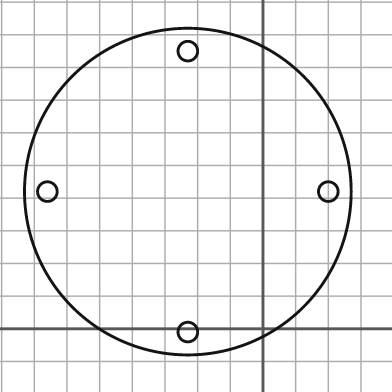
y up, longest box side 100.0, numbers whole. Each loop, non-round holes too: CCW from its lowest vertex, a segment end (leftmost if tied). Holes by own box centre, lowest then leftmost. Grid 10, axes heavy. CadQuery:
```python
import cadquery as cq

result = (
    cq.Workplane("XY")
    .moveTo(-23.0, 42.0)
    .circle(50.0)
    .moveTo(-23.0, -1.0)
    .circle(3.0)
    .moveTo(-66.0, 42.0)
    .circle(3.0)
    .moveTo(20.0, 42.0)
    .circle(3.0)
    .moveTo(-23.0, 85.0)
    .circle(3.0)
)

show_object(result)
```